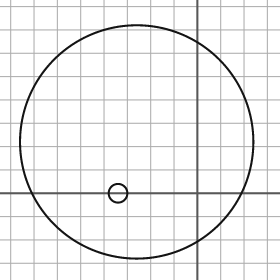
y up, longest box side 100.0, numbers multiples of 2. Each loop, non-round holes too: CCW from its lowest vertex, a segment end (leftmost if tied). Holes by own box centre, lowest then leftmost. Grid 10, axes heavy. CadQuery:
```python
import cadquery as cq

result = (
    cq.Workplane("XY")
    .moveTo(-26.0, 22.0)
    .circle(50.0)
    .moveTo(-34.0, 0.0)
    .circle(4.0)
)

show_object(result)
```